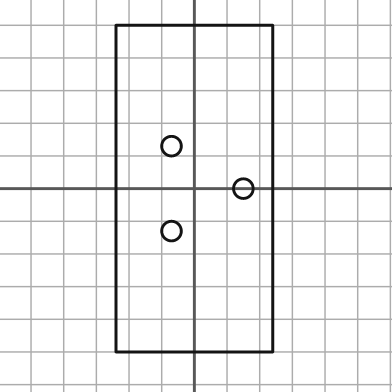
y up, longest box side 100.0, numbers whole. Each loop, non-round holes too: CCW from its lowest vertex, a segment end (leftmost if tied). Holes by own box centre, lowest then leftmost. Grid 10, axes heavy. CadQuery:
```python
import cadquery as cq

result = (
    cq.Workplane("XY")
    .moveTo(-24.0, -50.0)
    .lineTo(24.0, -50.0)
    .lineTo(24.0, 50.0)
    .lineTo(-24.0, 50.0)
    .close()
    .moveTo(-7.0, -13.0)
    .circle(3.0)
    .moveTo(15.0, 0.0)
    .circle(3.0)
    .moveTo(-7.0, 13.0)
    .circle(3.0)
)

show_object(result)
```